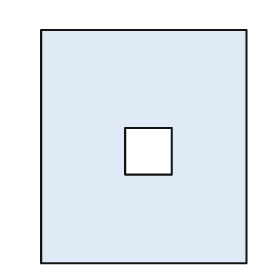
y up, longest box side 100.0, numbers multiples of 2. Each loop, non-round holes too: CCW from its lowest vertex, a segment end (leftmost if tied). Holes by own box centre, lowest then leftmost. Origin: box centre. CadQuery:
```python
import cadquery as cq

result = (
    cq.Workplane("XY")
    .moveTo(-44.0, -50.0)
    .lineTo(44.0, -50.0)
    .lineTo(44.0, 50.0)
    .lineTo(-44.0, 50.0)
    .close()
    .moveTo(-8.0, -12.0)
    .lineTo(12.0, -12.0)
    .lineTo(12.0, 8.0)
    .lineTo(-8.0, 8.0)
    .close()
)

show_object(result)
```